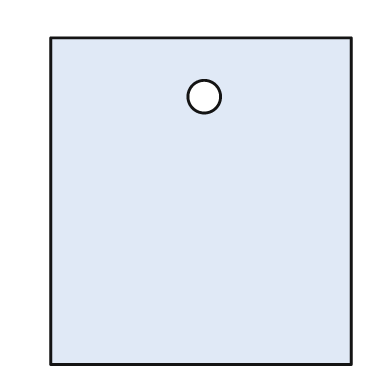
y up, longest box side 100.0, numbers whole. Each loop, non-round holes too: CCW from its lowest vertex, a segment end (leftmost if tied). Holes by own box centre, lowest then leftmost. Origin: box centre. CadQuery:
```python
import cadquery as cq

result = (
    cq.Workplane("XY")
    .moveTo(-46.0, -50.0)
    .lineTo(46.0, -50.0)
    .lineTo(46.0, 50.0)
    .lineTo(-46.0, 50.0)
    .close()
    .moveTo(1.0, 32.0)
    .circle(5.0)
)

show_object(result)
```